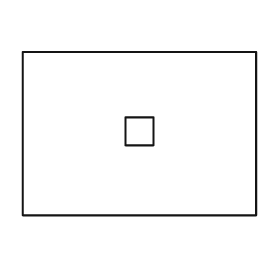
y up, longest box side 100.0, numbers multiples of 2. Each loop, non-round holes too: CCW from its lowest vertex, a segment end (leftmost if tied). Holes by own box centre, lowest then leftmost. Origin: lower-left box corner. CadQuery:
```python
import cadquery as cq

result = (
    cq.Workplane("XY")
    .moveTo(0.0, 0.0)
    .lineTo(100.0, 0.0)
    .lineTo(100.0, 70.0)
    .lineTo(0.0, 70.0)
    .close()
    .moveTo(44.0, 30.0)
    .lineTo(56.0, 30.0)
    .lineTo(56.0, 42.0)
    .lineTo(44.0, 42.0)
    .close()
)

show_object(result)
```